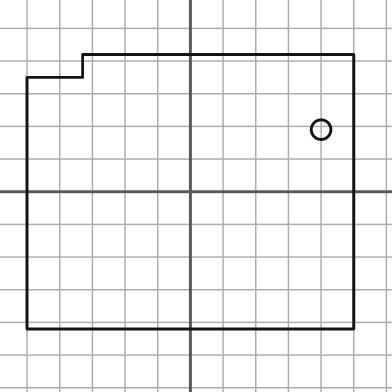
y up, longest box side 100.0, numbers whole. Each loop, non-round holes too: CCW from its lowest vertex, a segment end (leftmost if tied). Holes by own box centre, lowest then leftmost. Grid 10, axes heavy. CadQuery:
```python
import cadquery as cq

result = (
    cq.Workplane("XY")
    .moveTo(-50.0, -42.0)
    .lineTo(50.0, -42.0)
    .lineTo(50.0, 42.0)
    .lineTo(-33.0, 42.0)
    .lineTo(-33.0, 35.0)
    .lineTo(-50.0, 35.0)
    .close()
    .moveTo(40.0, 19.0)
    .circle(3.0)
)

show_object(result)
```